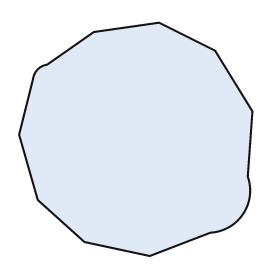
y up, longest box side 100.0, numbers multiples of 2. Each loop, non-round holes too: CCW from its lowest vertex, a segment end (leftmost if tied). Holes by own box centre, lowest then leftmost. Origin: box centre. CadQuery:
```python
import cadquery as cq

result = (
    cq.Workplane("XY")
    .moveTo(6.0, -50.0)
    .lineTo(32.0, -40.0)
    .threePointArc((46.0, -32.0), (48.0, -16.0))
    .lineTo(50.0, 12.0)
    .lineTo(34.0, 38.0)
    .lineTo(10.0, 50.0)
    .lineTo(-18.0, 46.0)
    .lineTo(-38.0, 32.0)
    .threePointArc((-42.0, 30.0), (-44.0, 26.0))
    .lineTo(-50.0, 2.0)
    .lineTo(-42.0, -26.0)
    .lineTo(-22.0, -44.0)
    .close()
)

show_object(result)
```